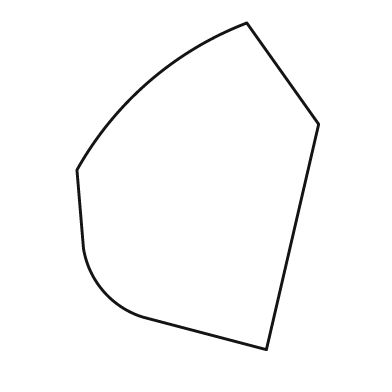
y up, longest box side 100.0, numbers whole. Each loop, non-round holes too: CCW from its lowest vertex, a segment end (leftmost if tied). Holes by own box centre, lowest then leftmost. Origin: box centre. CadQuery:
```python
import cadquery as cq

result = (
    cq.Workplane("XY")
    .moveTo(21.0, -50.0)
    .lineTo(37.0, 19.0)
    .lineTo(15.0, 50.0)
    .threePointArc((-15.0, 32.0), (-37.0, 5.0))
    .lineTo(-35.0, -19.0)
    .threePointArc((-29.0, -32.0), (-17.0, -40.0))
    .close()
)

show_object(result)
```